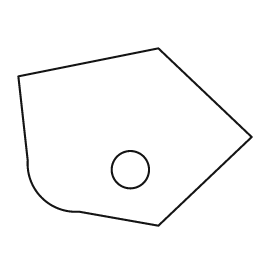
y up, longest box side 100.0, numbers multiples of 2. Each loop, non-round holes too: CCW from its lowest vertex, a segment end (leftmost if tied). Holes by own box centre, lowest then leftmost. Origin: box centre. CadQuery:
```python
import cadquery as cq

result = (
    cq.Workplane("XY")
    .moveTo(10.0, -38.0)
    .lineTo(50.0, 0.0)
    .lineTo(10.0, 38.0)
    .lineTo(-50.0, 26.0)
    .lineTo(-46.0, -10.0)
    .threePointArc((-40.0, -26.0), (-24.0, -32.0))
    .close()
    .moveTo(-2.0, -14.0)
    .circle(8.0)
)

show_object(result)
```